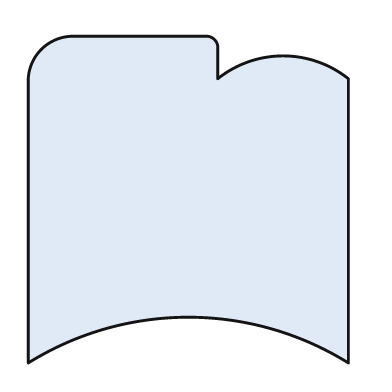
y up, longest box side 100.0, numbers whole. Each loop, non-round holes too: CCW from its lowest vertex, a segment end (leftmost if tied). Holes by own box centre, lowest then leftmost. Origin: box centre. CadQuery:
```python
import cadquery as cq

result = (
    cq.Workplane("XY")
    .moveTo(-49.0, -50.0)
    .threePointArc((0.0, -36.0), (49.0, -50.0))
    .lineTo(49.0, 37.0)
    .threePointArc((29.0, 44.0), (9.0, 37.0))
    .lineTo(9.0, 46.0)
    .threePointArc((8.0, 49.0), (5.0, 50.0))
    .lineTo(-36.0, 50.0)
    .threePointArc((-45.0, 46.0), (-49.0, 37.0))
    .close()
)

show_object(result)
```